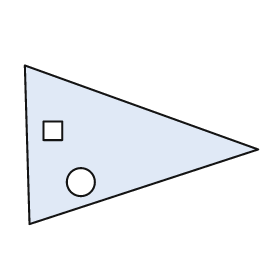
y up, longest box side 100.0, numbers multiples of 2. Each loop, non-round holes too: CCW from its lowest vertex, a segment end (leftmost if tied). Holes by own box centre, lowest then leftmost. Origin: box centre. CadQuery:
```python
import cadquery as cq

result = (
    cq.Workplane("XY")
    .moveTo(-48.0, -34.0)
    .lineTo(50.0, -2.0)
    .lineTo(-50.0, 34.0)
    .close()
    .moveTo(-26.0, -16.0)
    .circle(6.0)
    .moveTo(-42.0, 2.0)
    .lineTo(-34.0, 2.0)
    .lineTo(-34.0, 10.0)
    .lineTo(-42.0, 10.0)
    .close()
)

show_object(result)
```